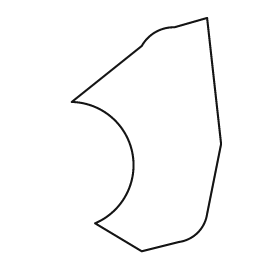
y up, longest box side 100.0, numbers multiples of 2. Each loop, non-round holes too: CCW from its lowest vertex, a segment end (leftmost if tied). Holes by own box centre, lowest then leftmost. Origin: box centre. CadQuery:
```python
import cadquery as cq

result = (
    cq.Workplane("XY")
    .moveTo(-2.0, -50.0)
    .lineTo(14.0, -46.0)
    .threePointArc((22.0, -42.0), (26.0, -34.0))
    .lineTo(32.0, -4.0)
    .lineTo(26.0, 50.0)
    .lineTo(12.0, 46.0)
    .threePointArc((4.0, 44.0), (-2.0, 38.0))
    .lineTo(-32.0, 14.0)
    .threePointArc((-6.0, -8.0), (-22.0, -38.0))
    .close()
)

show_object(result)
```